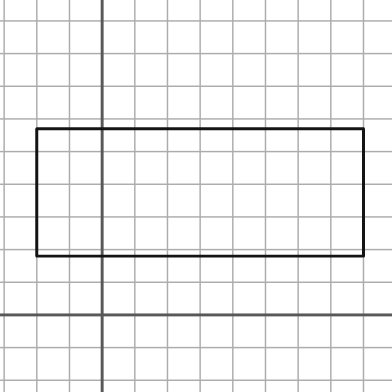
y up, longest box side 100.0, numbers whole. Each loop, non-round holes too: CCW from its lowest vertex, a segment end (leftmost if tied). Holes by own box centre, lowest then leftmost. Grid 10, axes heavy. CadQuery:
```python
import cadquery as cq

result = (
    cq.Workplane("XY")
    .moveTo(-20.0, 18.0)
    .lineTo(80.0, 18.0)
    .lineTo(80.0, 57.0)
    .lineTo(-20.0, 57.0)
    .close()
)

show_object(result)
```